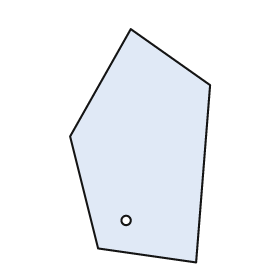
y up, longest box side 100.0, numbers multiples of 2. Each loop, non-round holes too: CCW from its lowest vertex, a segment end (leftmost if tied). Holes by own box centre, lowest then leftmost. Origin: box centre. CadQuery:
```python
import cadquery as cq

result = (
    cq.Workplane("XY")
    .moveTo(24.0, -50.0)
    .lineTo(30.0, 26.0)
    .lineTo(-4.0, 50.0)
    .lineTo(-30.0, 4.0)
    .lineTo(-18.0, -44.0)
    .close()
    .moveTo(-6.0, -32.0)
    .circle(2.0)
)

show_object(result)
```